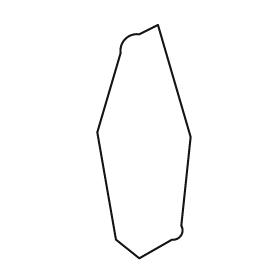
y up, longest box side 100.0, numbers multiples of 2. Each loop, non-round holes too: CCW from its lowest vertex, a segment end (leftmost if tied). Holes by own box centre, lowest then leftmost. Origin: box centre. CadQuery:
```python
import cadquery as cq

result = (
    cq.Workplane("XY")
    .moveTo(-2.0, -50.0)
    .lineTo(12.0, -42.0)
    .threePointArc((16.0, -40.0), (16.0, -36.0))
    .lineTo(20.0, 2.0)
    .lineTo(6.0, 50.0)
    .lineTo(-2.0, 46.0)
    .threePointArc((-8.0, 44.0), (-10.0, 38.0))
    .lineTo(-20.0, 4.0)
    .lineTo(-12.0, -42.0)
    .close()
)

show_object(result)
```